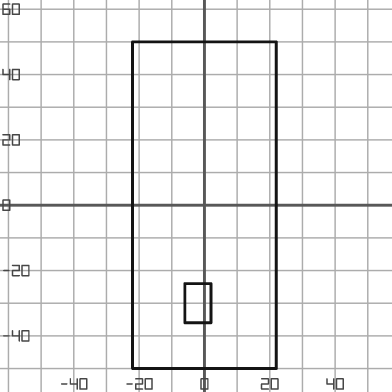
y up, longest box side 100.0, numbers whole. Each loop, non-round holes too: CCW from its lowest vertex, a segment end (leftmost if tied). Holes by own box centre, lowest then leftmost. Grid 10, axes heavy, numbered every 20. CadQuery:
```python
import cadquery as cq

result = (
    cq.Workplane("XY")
    .moveTo(-22.0, -50.0)
    .lineTo(22.0, -50.0)
    .lineTo(22.0, 50.0)
    .lineTo(-22.0, 50.0)
    .close()
    .moveTo(-6.0, -36.0)
    .lineTo(2.0, -36.0)
    .lineTo(2.0, -24.0)
    .lineTo(-6.0, -24.0)
    .close()
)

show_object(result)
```